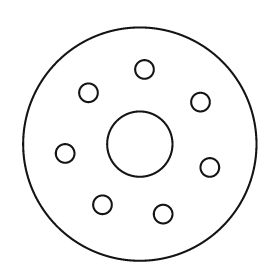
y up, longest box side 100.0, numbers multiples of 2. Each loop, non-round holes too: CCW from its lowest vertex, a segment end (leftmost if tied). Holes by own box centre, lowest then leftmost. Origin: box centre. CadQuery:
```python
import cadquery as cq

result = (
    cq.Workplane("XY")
    .moveTo(0.0, 0.0)
    .circle(50.0)
    .moveTo(10.0, -30.0)
    .circle(4.0)
    .moveTo(-16.0, -26.0)
    .circle(4.0)
    .moveTo(30.0, -10.0)
    .circle(4.0)
    .moveTo(-32.0, -4.0)
    .circle(4.0)
    .moveTo(0.0, 0.0)
    .circle(14.0)
    .moveTo(26.0, 18.0)
    .circle(4.0)
    .moveTo(-22.0, 22.0)
    .circle(4.0)
    .moveTo(2.0, 32.0)
    .circle(4.0)
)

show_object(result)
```